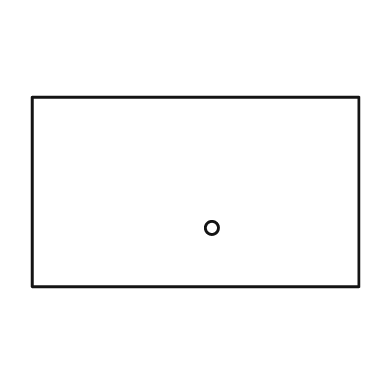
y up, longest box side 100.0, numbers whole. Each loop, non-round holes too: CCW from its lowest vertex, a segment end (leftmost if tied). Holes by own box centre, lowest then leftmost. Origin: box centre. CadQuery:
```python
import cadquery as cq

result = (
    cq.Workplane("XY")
    .moveTo(-50.0, -29.0)
    .lineTo(50.0, -29.0)
    .lineTo(50.0, 29.0)
    .lineTo(-50.0, 29.0)
    .close()
    .moveTo(5.0, -11.0)
    .circle(2.0)
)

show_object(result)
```